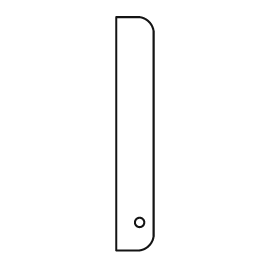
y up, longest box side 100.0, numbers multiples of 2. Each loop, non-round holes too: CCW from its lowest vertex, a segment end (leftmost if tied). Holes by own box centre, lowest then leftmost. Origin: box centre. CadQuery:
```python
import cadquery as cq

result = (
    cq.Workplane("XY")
    .moveTo(-8.0, -50.0)
    .lineTo(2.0, -50.0)
    .threePointArc((6.0, -48.0), (8.0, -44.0))
    .lineTo(8.0, 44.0)
    .threePointArc((6.0, 48.0), (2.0, 50.0))
    .lineTo(-8.0, 50.0)
    .close()
    .moveTo(2.0, -38.0)
    .circle(2.0)
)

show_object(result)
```